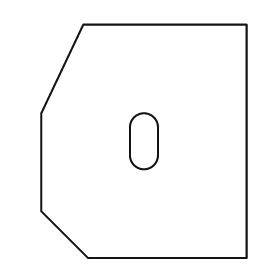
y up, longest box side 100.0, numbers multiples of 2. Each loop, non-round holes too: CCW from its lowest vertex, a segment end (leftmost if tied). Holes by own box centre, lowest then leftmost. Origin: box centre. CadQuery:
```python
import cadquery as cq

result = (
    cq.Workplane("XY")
    .moveTo(-24.0, -50.0)
    .lineTo(44.0, -50.0)
    .lineTo(44.0, 50.0)
    .lineTo(-26.0, 50.0)
    .lineTo(-44.0, 12.0)
    .lineTo(-44.0, -30.0)
    .close()
    .moveTo(-6.0, -6.0)
    .threePointArc((0.0, -12.0), (6.0, -6.0))
    .lineTo(6.0, 6.0)
    .threePointArc((0.0, 12.0), (-6.0, 6.0))
    .close()
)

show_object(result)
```